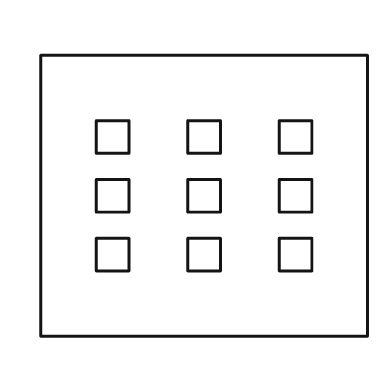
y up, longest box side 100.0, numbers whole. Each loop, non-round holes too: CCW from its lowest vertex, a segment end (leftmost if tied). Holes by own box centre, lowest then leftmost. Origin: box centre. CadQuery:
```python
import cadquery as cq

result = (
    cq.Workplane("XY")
    .moveTo(-50.0, -43.0)
    .lineTo(50.0, -43.0)
    .lineTo(50.0, 43.0)
    .lineTo(-50.0, 43.0)
    .close()
    .moveTo(-33.0, -23.0)
    .lineTo(-23.0, -23.0)
    .lineTo(-23.0, -13.0)
    .lineTo(-33.0, -13.0)
    .close()
    .moveTo(-5.0, -23.0)
    .lineTo(5.0, -23.0)
    .lineTo(5.0, -13.0)
    .lineTo(-5.0, -13.0)
    .close()
    .moveTo(23.0, -23.0)
    .lineTo(33.0, -23.0)
    .lineTo(33.0, -13.0)
    .lineTo(23.0, -13.0)
    .close()
    .moveTo(-33.0, -5.0)
    .lineTo(-23.0, -5.0)
    .lineTo(-23.0, 5.0)
    .lineTo(-33.0, 5.0)
    .close()
    .moveTo(-5.0, -5.0)
    .lineTo(5.0, -5.0)
    .lineTo(5.0, 5.0)
    .lineTo(-5.0, 5.0)
    .close()
    .moveTo(23.0, -5.0)
    .lineTo(33.0, -5.0)
    .lineTo(33.0, 5.0)
    .lineTo(23.0, 5.0)
    .close()
    .moveTo(-33.0, 13.0)
    .lineTo(-23.0, 13.0)
    .lineTo(-23.0, 23.0)
    .lineTo(-33.0, 23.0)
    .close()
    .moveTo(-5.0, 13.0)
    .lineTo(5.0, 13.0)
    .lineTo(5.0, 23.0)
    .lineTo(-5.0, 23.0)
    .close()
    .moveTo(23.0, 13.0)
    .lineTo(33.0, 13.0)
    .lineTo(33.0, 23.0)
    .lineTo(23.0, 23.0)
    .close()
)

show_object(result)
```